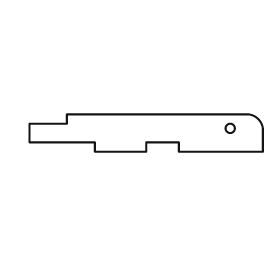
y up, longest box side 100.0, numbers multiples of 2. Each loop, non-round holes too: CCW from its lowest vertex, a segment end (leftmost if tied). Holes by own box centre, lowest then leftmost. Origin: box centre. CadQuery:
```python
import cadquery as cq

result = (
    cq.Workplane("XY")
    .moveTo(-22.0, -8.0)
    .lineTo(0.0, -8.0)
    .lineTo(0.0, -4.0)
    .lineTo(14.0, -4.0)
    .lineTo(14.0, -8.0)
    .lineTo(50.0, -8.0)
    .lineTo(50.0, 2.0)
    .threePointArc((48.0, 6.0), (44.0, 8.0))
    .lineTo(-34.0, 8.0)
    .lineTo(-34.0, 4.0)
    .lineTo(-50.0, 4.0)
    .lineTo(-50.0, -4.0)
    .lineTo(-22.0, -4.0)
    .close()
    .moveTo(36.0, 2.0)
    .circle(2.0)
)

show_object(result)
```